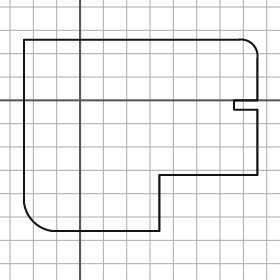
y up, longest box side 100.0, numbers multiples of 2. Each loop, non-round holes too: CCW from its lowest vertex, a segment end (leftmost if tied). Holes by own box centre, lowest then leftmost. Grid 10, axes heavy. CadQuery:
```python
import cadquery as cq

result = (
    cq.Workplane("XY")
    .moveTo(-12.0, -56.0)
    .lineTo(34.0, -56.0)
    .lineTo(34.0, -32.0)
    .lineTo(76.0, -32.0)
    .lineTo(76.0, -4.0)
    .lineTo(66.0, -4.0)
    .lineTo(66.0, 0.0)
    .lineTo(76.0, 0.0)
    .lineTo(76.0, 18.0)
    .threePointArc((74.0, 24.0), (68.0, 26.0))
    .lineTo(-24.0, 26.0)
    .lineTo(-24.0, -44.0)
    .threePointArc((-20.0, -52.0), (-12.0, -56.0))
    .close()
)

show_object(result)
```